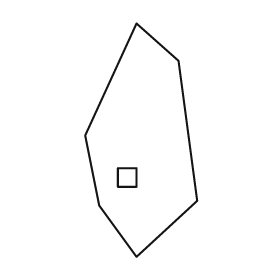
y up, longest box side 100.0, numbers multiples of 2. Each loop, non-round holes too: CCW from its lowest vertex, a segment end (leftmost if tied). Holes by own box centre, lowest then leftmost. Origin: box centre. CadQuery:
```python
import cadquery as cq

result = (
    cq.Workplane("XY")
    .moveTo(-2.0, -50.0)
    .lineTo(24.0, -26.0)
    .lineTo(16.0, 34.0)
    .lineTo(-2.0, 50.0)
    .lineTo(-24.0, 2.0)
    .lineTo(-18.0, -28.0)
    .close()
    .moveTo(-10.0, -20.0)
    .lineTo(-2.0, -20.0)
    .lineTo(-2.0, -12.0)
    .lineTo(-10.0, -12.0)
    .close()
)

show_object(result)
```